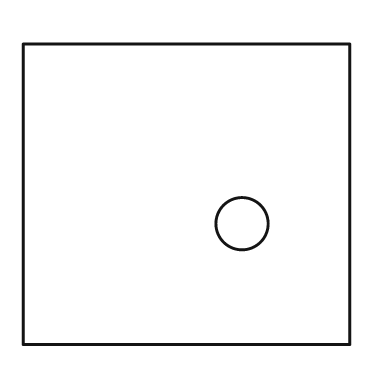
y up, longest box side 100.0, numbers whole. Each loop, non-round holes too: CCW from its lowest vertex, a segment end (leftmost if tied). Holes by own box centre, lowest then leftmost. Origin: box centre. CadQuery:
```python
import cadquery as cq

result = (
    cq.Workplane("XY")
    .moveTo(-50.0, -46.0)
    .lineTo(50.0, -46.0)
    .lineTo(50.0, 46.0)
    .lineTo(-50.0, 46.0)
    .close()
    .moveTo(17.0, -9.0)
    .circle(8.0)
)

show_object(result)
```